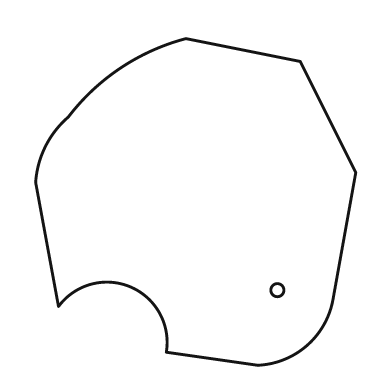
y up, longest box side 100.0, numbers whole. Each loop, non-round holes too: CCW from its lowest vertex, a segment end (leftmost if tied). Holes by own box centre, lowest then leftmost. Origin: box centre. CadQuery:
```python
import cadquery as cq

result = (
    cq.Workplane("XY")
    .moveTo(19.0, -50.0)
    .threePointArc((34.0, -44.0), (42.0, -30.0))
    .lineTo(49.0, 9.0)
    .lineTo(32.0, 43.0)
    .lineTo(-3.0, 50.0)
    .threePointArc((-23.0, 41.0), (-39.0, 26.0))
    .threePointArc((-46.0, 17.0), (-49.0, 6.0))
    .lineTo(-42.0, -32.0)
    .threePointArc((-20.0, -26.0), (-9.0, -46.0))
    .close()
    .moveTo(25.0, -27.0)
    .circle(2.0)
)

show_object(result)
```